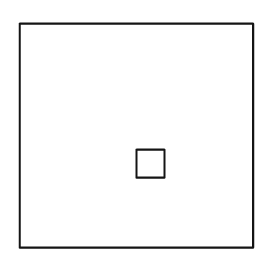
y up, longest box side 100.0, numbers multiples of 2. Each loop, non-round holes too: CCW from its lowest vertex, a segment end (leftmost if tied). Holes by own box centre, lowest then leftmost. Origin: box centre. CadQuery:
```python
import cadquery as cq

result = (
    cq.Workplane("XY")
    .moveTo(-50.0, -48.0)
    .lineTo(50.0, -48.0)
    .lineTo(50.0, 48.0)
    .lineTo(-50.0, 48.0)
    .close()
    .moveTo(0.0, -18.0)
    .lineTo(12.0, -18.0)
    .lineTo(12.0, -6.0)
    .lineTo(0.0, -6.0)
    .close()
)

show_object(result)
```